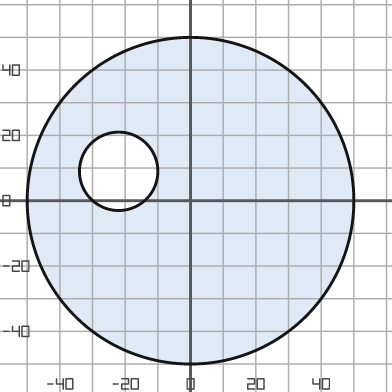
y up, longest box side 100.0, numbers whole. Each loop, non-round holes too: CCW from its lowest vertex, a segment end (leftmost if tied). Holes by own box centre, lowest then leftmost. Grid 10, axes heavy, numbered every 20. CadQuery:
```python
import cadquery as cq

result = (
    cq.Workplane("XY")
    .moveTo(0.0, 0.0)
    .circle(50.0)
    .moveTo(-22.0, 9.0)
    .circle(12.0)
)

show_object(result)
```